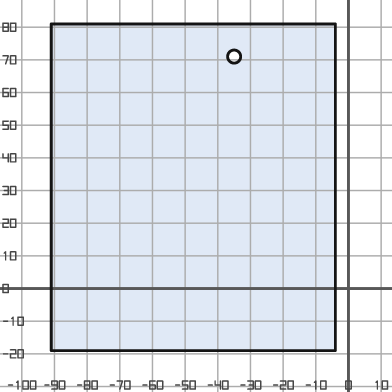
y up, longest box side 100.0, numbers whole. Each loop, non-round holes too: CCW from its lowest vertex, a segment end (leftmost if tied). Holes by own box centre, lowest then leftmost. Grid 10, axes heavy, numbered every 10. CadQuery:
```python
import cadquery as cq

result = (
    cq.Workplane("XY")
    .moveTo(-91.0, -19.0)
    .lineTo(-4.0, -19.0)
    .lineTo(-4.0, 81.0)
    .lineTo(-91.0, 81.0)
    .close()
    .moveTo(-35.0, 71.0)
    .circle(2.0)
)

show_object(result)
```